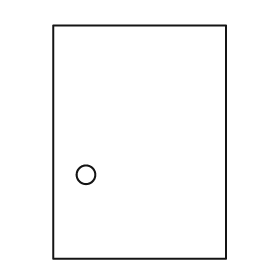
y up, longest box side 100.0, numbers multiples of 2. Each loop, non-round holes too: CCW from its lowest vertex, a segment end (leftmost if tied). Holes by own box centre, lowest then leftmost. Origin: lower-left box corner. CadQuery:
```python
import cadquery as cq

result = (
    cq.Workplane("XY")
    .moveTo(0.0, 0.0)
    .lineTo(74.0, 0.0)
    .lineTo(74.0, 100.0)
    .lineTo(0.0, 100.0)
    .close()
    .moveTo(14.0, 36.0)
    .circle(4.0)
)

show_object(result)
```